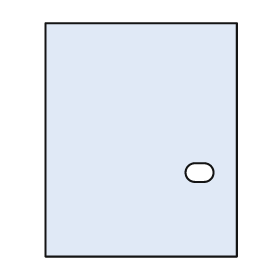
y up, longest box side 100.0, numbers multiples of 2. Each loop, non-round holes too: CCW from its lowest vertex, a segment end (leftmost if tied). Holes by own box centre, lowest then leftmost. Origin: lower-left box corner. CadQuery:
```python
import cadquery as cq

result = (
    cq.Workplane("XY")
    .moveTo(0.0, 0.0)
    .lineTo(82.0, 0.0)
    .lineTo(82.0, 100.0)
    .lineTo(0.0, 100.0)
    .close()
    .moveTo(64.0, 32.0)
    .lineTo(68.0, 32.0)
    .threePointArc((72.0, 36.0), (68.0, 40.0))
    .lineTo(64.0, 40.0)
    .threePointArc((60.0, 36.0), (64.0, 32.0))
    .close()
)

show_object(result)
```